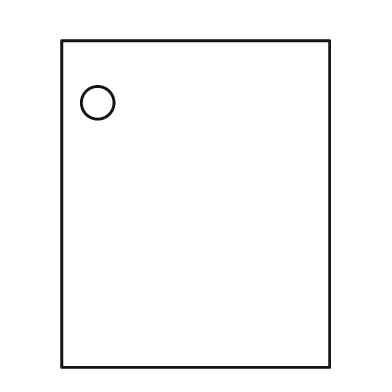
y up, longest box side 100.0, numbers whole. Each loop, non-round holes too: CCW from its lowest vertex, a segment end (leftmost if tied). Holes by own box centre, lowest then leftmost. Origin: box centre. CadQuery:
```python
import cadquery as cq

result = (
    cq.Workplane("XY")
    .moveTo(-41.0, -50.0)
    .lineTo(41.0, -50.0)
    .lineTo(41.0, 50.0)
    .lineTo(-41.0, 50.0)
    .close()
    .moveTo(-30.0, 31.0)
    .circle(5.0)
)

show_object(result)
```